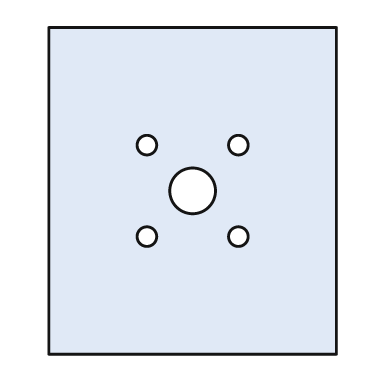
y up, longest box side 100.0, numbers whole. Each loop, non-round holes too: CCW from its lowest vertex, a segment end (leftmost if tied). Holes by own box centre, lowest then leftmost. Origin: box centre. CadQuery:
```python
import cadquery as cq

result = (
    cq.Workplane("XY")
    .moveTo(-44.0, -50.0)
    .lineTo(44.0, -50.0)
    .lineTo(44.0, 50.0)
    .lineTo(-44.0, 50.0)
    .close()
    .moveTo(-14.0, -14.0)
    .circle(3.0)
    .moveTo(14.0, -14.0)
    .circle(3.0)
    .moveTo(0.0, 0.0)
    .circle(7.0)
    .moveTo(-14.0, 14.0)
    .circle(3.0)
    .moveTo(14.0, 14.0)
    .circle(3.0)
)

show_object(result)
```